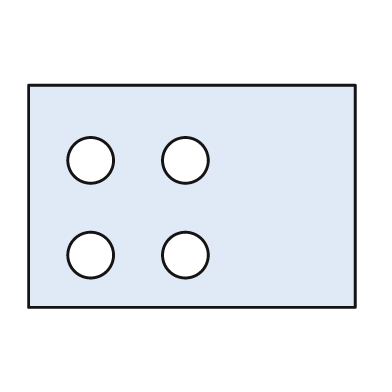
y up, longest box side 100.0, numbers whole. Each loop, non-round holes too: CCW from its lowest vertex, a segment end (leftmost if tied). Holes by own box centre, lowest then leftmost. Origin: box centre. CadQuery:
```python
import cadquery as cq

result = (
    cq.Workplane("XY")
    .moveTo(-50.0, -34.0)
    .lineTo(50.0, -34.0)
    .lineTo(50.0, 34.0)
    .lineTo(-50.0, 34.0)
    .close()
    .moveTo(-31.0, -18.0)
    .circle(7.0)
    .moveTo(-2.0, -18.0)
    .circle(7.0)
    .moveTo(-31.0, 11.0)
    .circle(7.0)
    .moveTo(-2.0, 11.0)
    .circle(7.0)
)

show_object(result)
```